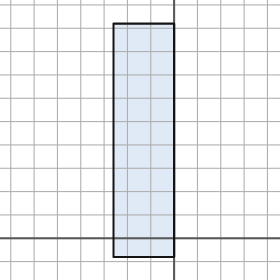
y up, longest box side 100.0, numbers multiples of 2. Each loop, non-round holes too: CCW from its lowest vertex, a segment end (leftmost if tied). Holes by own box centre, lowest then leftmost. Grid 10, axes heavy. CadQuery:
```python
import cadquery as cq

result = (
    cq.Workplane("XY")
    .moveTo(-26.0, -8.0)
    .lineTo(0.0, -8.0)
    .lineTo(0.0, 92.0)
    .lineTo(-26.0, 92.0)
    .close()
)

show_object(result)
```